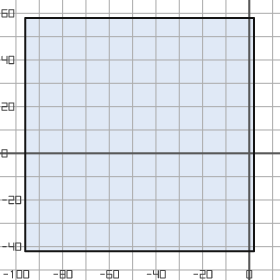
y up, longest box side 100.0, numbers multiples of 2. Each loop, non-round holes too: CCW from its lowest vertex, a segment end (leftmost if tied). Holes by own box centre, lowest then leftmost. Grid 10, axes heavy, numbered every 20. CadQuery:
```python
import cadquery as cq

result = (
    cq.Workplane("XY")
    .moveTo(-96.0, -42.0)
    .lineTo(2.0, -42.0)
    .lineTo(2.0, 58.0)
    .lineTo(-96.0, 58.0)
    .close()
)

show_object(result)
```